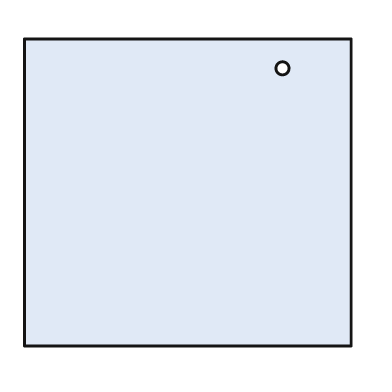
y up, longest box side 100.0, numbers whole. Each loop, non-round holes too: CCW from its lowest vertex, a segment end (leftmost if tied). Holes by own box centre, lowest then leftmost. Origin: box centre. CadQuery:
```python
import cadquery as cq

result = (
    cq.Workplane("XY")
    .moveTo(-50.0, -47.0)
    .lineTo(50.0, -47.0)
    .lineTo(50.0, 47.0)
    .lineTo(-50.0, 47.0)
    .close()
    .moveTo(29.0, 38.0)
    .circle(2.0)
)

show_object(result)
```